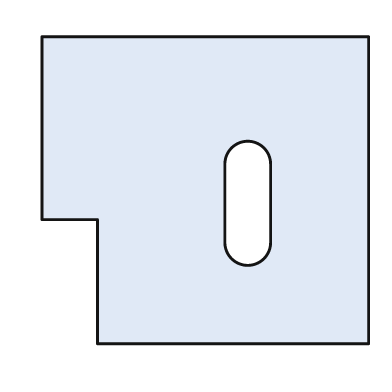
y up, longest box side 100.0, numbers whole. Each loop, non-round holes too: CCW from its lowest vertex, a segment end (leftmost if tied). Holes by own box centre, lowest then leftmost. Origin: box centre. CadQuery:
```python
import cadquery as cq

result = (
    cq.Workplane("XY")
    .moveTo(-33.0, -47.0)
    .lineTo(50.0, -47.0)
    .lineTo(50.0, 47.0)
    .lineTo(-50.0, 47.0)
    .lineTo(-50.0, -9.0)
    .lineTo(-33.0, -9.0)
    .close()
    .moveTo(6.0, -16.0)
    .threePointArc((13.0, -23.0), (20.0, -16.0))
    .lineTo(20.0, 8.0)
    .threePointArc((13.0, 15.0), (6.0, 8.0))
    .close()
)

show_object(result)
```